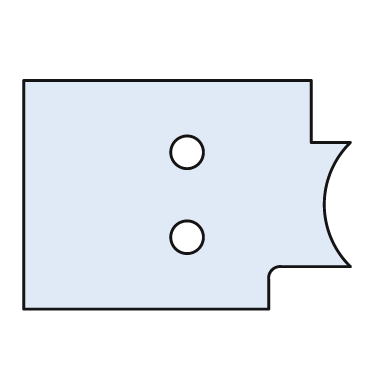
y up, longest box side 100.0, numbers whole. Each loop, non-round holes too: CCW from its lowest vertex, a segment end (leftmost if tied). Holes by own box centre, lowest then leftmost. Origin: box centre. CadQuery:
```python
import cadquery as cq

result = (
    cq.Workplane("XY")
    .moveTo(-50.0, -35.0)
    .lineTo(25.0, -35.0)
    .lineTo(25.0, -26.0)
    .threePointArc((26.0, -23.0), (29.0, -22.0))
    .lineTo(50.0, -22.0)
    .threePointArc((42.0, -3.0), (50.0, 16.0))
    .lineTo(38.0, 16.0)
    .lineTo(38.0, 35.0)
    .lineTo(-50.0, 35.0)
    .close()
    .moveTo(0.0, -13.0)
    .circle(5.0)
    .moveTo(0.0, 13.0)
    .circle(5.0)
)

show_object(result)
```